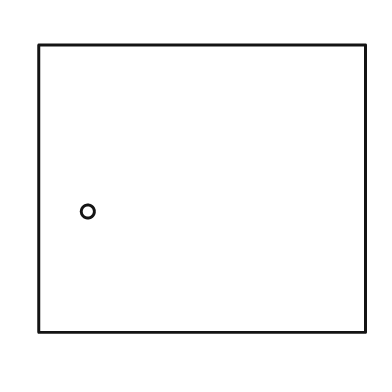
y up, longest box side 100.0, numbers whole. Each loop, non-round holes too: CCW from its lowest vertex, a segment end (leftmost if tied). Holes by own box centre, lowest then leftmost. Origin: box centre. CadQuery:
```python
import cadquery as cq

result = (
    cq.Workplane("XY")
    .moveTo(-50.0, -44.0)
    .lineTo(50.0, -44.0)
    .lineTo(50.0, 44.0)
    .lineTo(-50.0, 44.0)
    .close()
    .moveTo(-35.0, -7.0)
    .circle(2.0)
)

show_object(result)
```